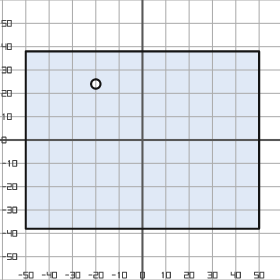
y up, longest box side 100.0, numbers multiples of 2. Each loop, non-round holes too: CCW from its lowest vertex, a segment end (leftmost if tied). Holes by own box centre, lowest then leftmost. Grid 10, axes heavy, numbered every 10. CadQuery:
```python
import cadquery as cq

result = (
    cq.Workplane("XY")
    .moveTo(-50.0, -38.0)
    .lineTo(50.0, -38.0)
    .lineTo(50.0, 38.0)
    .lineTo(-50.0, 38.0)
    .close()
    .moveTo(-20.0, 24.0)
    .circle(2.0)
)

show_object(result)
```